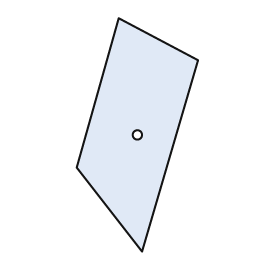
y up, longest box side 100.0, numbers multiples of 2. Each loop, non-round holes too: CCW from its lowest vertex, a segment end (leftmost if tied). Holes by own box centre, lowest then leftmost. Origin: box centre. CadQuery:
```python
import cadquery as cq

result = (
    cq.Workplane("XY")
    .moveTo(2.0, -50.0)
    .lineTo(26.0, 32.0)
    .lineTo(-8.0, 50.0)
    .lineTo(-26.0, -14.0)
    .close()
    .moveTo(0.0, 0.0)
    .circle(2.0)
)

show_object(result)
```